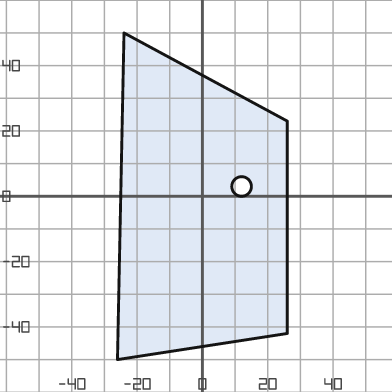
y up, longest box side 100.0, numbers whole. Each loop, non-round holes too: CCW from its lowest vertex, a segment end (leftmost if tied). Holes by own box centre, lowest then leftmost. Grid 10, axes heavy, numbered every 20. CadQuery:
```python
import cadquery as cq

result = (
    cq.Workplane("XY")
    .moveTo(-26.0, -50.0)
    .lineTo(26.0, -42.0)
    .lineTo(26.0, 23.0)
    .lineTo(-24.0, 50.0)
    .close()
    .moveTo(12.0, 3.0)
    .circle(3.0)
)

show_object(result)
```